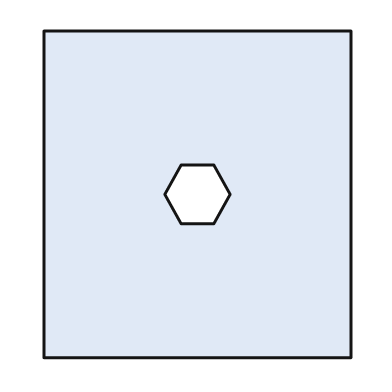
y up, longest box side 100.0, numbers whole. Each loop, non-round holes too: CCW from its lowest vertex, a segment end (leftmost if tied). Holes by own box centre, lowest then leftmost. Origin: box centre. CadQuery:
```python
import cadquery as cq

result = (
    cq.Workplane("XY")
    .moveTo(-47.0, -50.0)
    .lineTo(47.0, -50.0)
    .lineTo(47.0, 50.0)
    .lineTo(-47.0, 50.0)
    .close()
    .moveTo(-5.0, -9.0)
    .lineTo(5.0, -9.0)
    .lineTo(10.0, 0.0)
    .lineTo(5.0, 9.0)
    .lineTo(-5.0, 9.0)
    .lineTo(-10.0, 0.0)
    .close()
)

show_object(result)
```